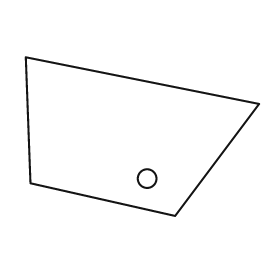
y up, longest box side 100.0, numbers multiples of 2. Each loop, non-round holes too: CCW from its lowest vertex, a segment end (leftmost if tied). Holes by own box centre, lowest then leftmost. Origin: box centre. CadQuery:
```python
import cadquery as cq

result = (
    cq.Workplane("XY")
    .moveTo(14.0, -34.0)
    .lineTo(50.0, 14.0)
    .lineTo(-50.0, 34.0)
    .lineTo(-48.0, -20.0)
    .close()
    .moveTo(2.0, -18.0)
    .circle(4.0)
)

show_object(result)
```